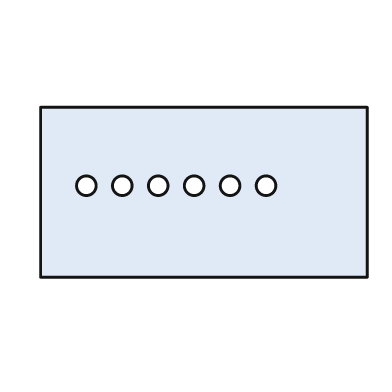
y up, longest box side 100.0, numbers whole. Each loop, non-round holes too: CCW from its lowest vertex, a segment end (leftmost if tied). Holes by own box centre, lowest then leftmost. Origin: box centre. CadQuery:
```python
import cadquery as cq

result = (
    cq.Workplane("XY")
    .moveTo(-50.0, -26.0)
    .lineTo(50.0, -26.0)
    .lineTo(50.0, 26.0)
    .lineTo(-50.0, 26.0)
    .close()
    .moveTo(-36.0, 2.0)
    .circle(3.0)
    .moveTo(-25.0, 2.0)
    .circle(3.0)
    .moveTo(-14.0, 2.0)
    .circle(3.0)
    .moveTo(-3.0, 2.0)
    .circle(3.0)
    .moveTo(8.0, 2.0)
    .circle(3.0)
    .moveTo(19.0, 2.0)
    .circle(3.0)
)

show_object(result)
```